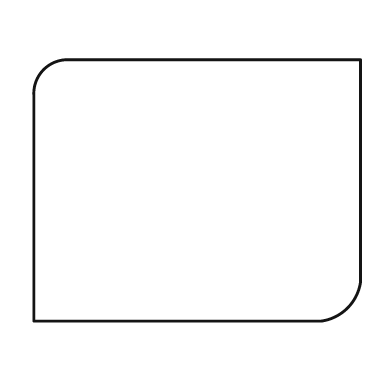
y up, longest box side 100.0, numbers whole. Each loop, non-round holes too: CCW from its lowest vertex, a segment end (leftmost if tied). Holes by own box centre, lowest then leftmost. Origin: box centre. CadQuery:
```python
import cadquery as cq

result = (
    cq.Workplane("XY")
    .moveTo(-50.0, -40.0)
    .lineTo(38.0, -40.0)
    .threePointArc((46.0, -36.0), (50.0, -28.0))
    .lineTo(50.0, 40.0)
    .lineTo(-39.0, 40.0)
    .threePointArc((-47.0, 37.0), (-50.0, 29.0))
    .close()
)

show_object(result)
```